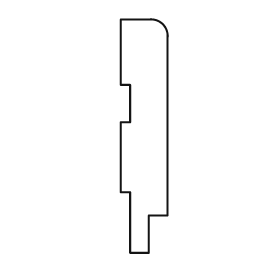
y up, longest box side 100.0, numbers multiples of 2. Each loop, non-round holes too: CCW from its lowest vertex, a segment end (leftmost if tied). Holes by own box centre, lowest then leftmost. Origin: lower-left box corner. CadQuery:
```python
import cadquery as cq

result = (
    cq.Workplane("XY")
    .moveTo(4.0, 0.0)
    .lineTo(12.0, 0.0)
    .lineTo(12.0, 16.0)
    .lineTo(20.0, 16.0)
    .lineTo(20.0, 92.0)
    .threePointArc((18.0, 98.0), (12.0, 100.0))
    .lineTo(0.0, 100.0)
    .lineTo(0.0, 72.0)
    .lineTo(4.0, 72.0)
    .lineTo(4.0, 56.0)
    .lineTo(0.0, 56.0)
    .lineTo(0.0, 26.0)
    .lineTo(4.0, 26.0)
    .close()
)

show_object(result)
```